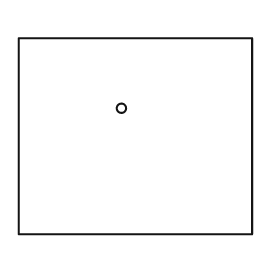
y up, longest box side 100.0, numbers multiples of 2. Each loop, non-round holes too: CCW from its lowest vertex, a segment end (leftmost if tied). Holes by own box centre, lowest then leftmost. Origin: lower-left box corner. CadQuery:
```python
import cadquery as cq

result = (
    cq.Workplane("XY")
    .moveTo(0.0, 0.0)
    .lineTo(100.0, 0.0)
    .lineTo(100.0, 84.0)
    .lineTo(0.0, 84.0)
    .close()
    .moveTo(44.0, 54.0)
    .circle(2.0)
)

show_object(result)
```